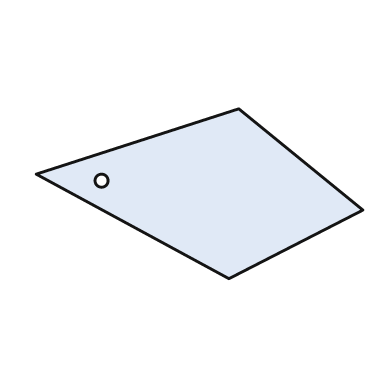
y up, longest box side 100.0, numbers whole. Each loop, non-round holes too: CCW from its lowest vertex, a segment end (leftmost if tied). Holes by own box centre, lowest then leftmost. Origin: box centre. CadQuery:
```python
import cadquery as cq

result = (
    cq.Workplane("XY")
    .moveTo(9.0, -26.0)
    .lineTo(50.0, -5.0)
    .lineTo(12.0, 26.0)
    .lineTo(-50.0, 6.0)
    .close()
    .moveTo(-30.0, 4.0)
    .circle(2.0)
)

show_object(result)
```